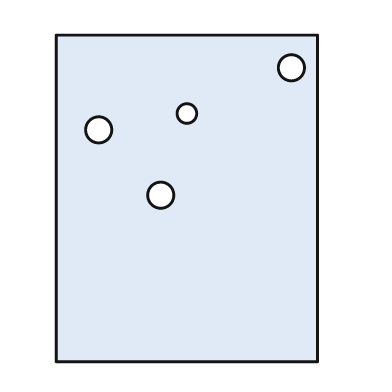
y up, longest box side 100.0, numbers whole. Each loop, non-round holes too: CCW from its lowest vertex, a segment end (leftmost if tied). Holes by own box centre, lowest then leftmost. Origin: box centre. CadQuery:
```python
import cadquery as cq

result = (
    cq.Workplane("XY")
    .moveTo(-40.0, -50.0)
    .lineTo(40.0, -50.0)
    .lineTo(40.0, 50.0)
    .lineTo(-40.0, 50.0)
    .close()
    .moveTo(-8.0, 1.0)
    .circle(4.0)
    .moveTo(-27.0, 21.0)
    .circle(4.0)
    .moveTo(0.0, 26.0)
    .circle(3.0)
    .moveTo(32.0, 40.0)
    .circle(4.0)
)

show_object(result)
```